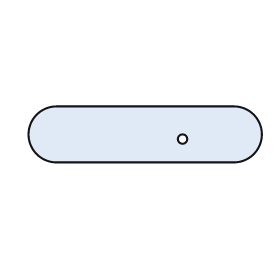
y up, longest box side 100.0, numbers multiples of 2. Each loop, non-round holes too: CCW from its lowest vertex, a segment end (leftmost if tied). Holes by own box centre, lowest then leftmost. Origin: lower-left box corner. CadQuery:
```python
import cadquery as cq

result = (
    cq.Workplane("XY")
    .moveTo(12.0, 0.0)
    .lineTo(88.0, 0.0)
    .threePointArc((100.0, 12.0), (88.0, 24.0))
    .lineTo(12.0, 24.0)
    .threePointArc((0.0, 12.0), (12.0, 0.0))
    .close()
    .moveTo(66.0, 10.0)
    .circle(2.0)
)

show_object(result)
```